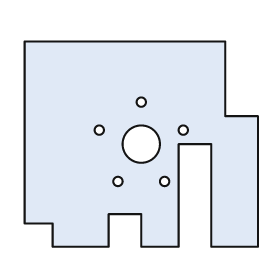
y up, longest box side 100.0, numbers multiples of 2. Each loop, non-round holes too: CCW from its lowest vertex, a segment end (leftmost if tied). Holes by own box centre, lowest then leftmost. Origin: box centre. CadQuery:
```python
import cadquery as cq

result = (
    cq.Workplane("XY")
    .moveTo(-38.0, -44.0)
    .lineTo(-14.0, -44.0)
    .lineTo(-14.0, -30.0)
    .lineTo(0.0, -30.0)
    .lineTo(0.0, -44.0)
    .lineTo(16.0, -44.0)
    .lineTo(16.0, 0.0)
    .lineTo(30.0, 0.0)
    .lineTo(30.0, -44.0)
    .lineTo(50.0, -44.0)
    .lineTo(50.0, 12.0)
    .lineTo(36.0, 12.0)
    .lineTo(36.0, 44.0)
    .lineTo(-50.0, 44.0)
    .lineTo(-50.0, -34.0)
    .lineTo(-38.0, -34.0)
    .close()
    .moveTo(-10.0, -16.0)
    .circle(2.0)
    .moveTo(10.0, -16.0)
    .circle(2.0)
    .moveTo(0.0, 0.0)
    .circle(8.0)
    .moveTo(-18.0, 6.0)
    .circle(2.0)
    .moveTo(18.0, 6.0)
    .circle(2.0)
    .moveTo(0.0, 18.0)
    .circle(2.0)
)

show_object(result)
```